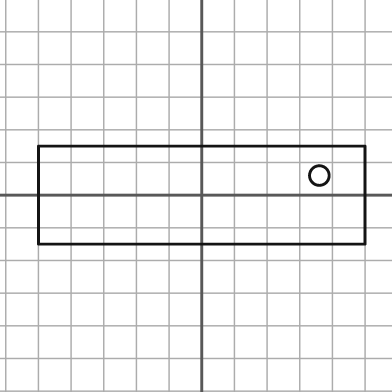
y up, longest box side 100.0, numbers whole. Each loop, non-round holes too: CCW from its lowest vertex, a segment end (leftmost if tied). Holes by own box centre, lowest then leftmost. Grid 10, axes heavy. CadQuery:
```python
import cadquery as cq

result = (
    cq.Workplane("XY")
    .moveTo(-50.0, -15.0)
    .lineTo(50.0, -15.0)
    .lineTo(50.0, 15.0)
    .lineTo(-50.0, 15.0)
    .close()
    .moveTo(36.0, 6.0)
    .circle(3.0)
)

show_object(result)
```